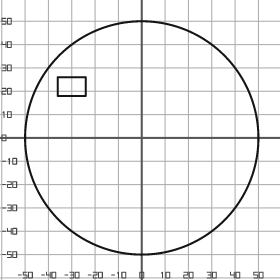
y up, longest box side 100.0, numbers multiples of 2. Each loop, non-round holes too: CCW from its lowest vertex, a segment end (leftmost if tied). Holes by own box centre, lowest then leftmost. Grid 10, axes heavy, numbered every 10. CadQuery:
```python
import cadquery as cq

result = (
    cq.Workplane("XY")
    .moveTo(0.0, 0.0)
    .circle(50.0)
    .moveTo(-36.0, 18.0)
    .lineTo(-24.0, 18.0)
    .lineTo(-24.0, 26.0)
    .lineTo(-36.0, 26.0)
    .close()
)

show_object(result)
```